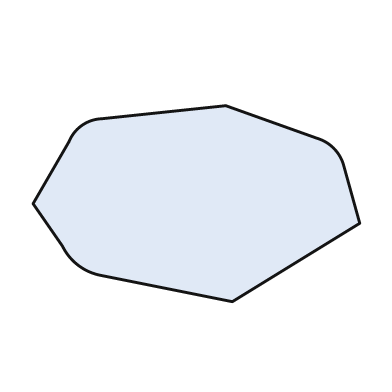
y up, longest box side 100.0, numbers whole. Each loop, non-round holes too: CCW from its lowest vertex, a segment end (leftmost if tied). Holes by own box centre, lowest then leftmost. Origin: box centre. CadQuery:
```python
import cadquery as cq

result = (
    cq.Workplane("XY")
    .moveTo(11.0, -30.0)
    .lineTo(50.0, -6.0)
    .lineTo(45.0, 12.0)
    .threePointArc((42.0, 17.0), (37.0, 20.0))
    .lineTo(9.0, 30.0)
    .lineTo(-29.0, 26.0)
    .threePointArc((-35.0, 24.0), (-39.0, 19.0))
    .lineTo(-50.0, 0.0)
    .lineTo(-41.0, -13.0)
    .threePointArc((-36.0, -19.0), (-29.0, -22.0))
    .close()
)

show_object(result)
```